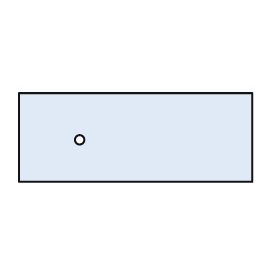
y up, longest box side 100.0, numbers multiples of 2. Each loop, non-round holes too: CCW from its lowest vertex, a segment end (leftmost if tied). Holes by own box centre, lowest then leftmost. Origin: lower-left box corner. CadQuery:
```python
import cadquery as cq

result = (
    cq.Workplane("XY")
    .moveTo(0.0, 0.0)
    .lineTo(100.0, 0.0)
    .lineTo(100.0, 38.0)
    .lineTo(0.0, 38.0)
    .close()
    .moveTo(26.0, 18.0)
    .circle(2.0)
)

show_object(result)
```